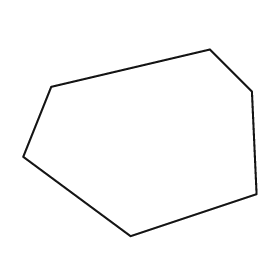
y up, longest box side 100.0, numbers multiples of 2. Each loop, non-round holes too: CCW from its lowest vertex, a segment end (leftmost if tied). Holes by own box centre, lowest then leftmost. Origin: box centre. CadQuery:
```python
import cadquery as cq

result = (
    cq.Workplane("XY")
    .moveTo(-4.0, -40.0)
    .lineTo(50.0, -22.0)
    .lineTo(48.0, 22.0)
    .lineTo(30.0, 40.0)
    .lineTo(-38.0, 24.0)
    .lineTo(-50.0, -6.0)
    .close()
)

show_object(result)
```